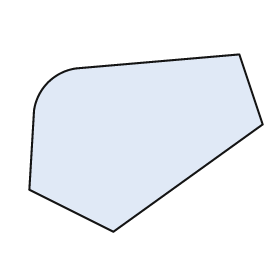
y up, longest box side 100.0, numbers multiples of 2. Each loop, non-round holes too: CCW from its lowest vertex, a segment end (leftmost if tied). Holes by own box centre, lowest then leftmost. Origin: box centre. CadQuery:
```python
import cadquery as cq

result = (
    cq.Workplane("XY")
    .moveTo(-14.0, -38.0)
    .lineTo(50.0, 8.0)
    .lineTo(40.0, 38.0)
    .lineTo(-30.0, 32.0)
    .threePointArc((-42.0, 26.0), (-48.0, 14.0))
    .lineTo(-50.0, -20.0)
    .close()
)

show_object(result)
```